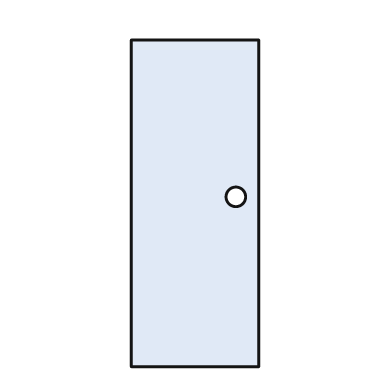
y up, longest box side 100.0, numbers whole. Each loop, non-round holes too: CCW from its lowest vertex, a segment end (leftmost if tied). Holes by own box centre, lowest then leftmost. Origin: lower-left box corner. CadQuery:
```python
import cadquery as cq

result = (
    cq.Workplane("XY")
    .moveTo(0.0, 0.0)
    .lineTo(39.0, 0.0)
    .lineTo(39.0, 100.0)
    .lineTo(0.0, 100.0)
    .close()
    .moveTo(32.0, 52.0)
    .circle(3.0)
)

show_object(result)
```